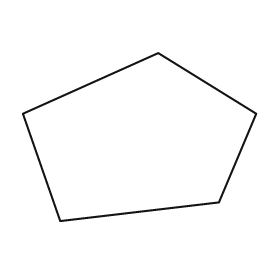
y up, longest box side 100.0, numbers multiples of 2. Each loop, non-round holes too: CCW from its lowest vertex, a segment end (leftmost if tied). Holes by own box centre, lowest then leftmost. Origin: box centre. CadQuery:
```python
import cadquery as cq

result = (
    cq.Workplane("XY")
    .moveTo(-34.0, -36.0)
    .lineTo(34.0, -28.0)
    .lineTo(50.0, 10.0)
    .lineTo(8.0, 36.0)
    .lineTo(-50.0, 10.0)
    .close()
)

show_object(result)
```